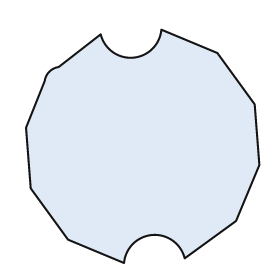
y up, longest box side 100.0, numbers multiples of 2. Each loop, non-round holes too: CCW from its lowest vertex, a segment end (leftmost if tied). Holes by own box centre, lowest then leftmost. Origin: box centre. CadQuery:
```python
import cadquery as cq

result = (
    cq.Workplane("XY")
    .moveTo(-8.0, -50.0)
    .threePointArc((4.0, -38.0), (18.0, -48.0))
    .lineTo(40.0, -32.0)
    .lineTo(50.0, -8.0)
    .lineTo(48.0, 18.0)
    .lineTo(32.0, 40.0)
    .lineTo(8.0, 50.0)
    .threePointArc((-4.0, 38.0), (-18.0, 48.0))
    .lineTo(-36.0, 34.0)
    .threePointArc((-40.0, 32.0), (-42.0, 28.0))
    .lineTo(-50.0, 8.0)
    .lineTo(-48.0, -18.0)
    .lineTo(-32.0, -40.0)
    .close()
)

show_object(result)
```